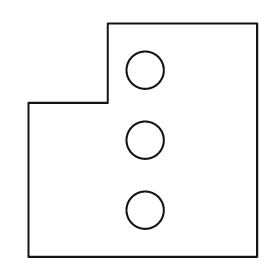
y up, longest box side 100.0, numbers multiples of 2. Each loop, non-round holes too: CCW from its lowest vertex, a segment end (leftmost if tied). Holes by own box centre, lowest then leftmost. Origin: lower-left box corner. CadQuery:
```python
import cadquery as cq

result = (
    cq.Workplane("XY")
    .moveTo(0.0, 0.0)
    .lineTo(98.0, 0.0)
    .lineTo(98.0, 100.0)
    .lineTo(34.0, 100.0)
    .lineTo(34.0, 66.0)
    .lineTo(0.0, 66.0)
    .close()
    .moveTo(50.0, 20.0)
    .circle(8.0)
    .moveTo(50.0, 50.0)
    .circle(8.0)
    .moveTo(50.0, 80.0)
    .circle(8.0)
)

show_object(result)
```